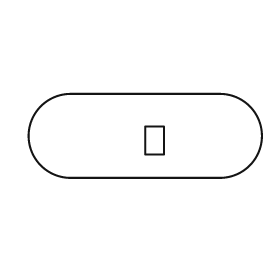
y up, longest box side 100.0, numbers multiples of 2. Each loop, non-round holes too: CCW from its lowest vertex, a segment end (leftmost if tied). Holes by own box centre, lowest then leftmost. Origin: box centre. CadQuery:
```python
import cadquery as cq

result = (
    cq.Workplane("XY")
    .moveTo(-32.0, -18.0)
    .lineTo(32.0, -18.0)
    .threePointArc((50.0, 0.0), (32.0, 18.0))
    .lineTo(-32.0, 18.0)
    .threePointArc((-50.0, 0.0), (-32.0, -18.0))
    .close()
    .moveTo(0.0, -8.0)
    .lineTo(8.0, -8.0)
    .lineTo(8.0, 4.0)
    .lineTo(0.0, 4.0)
    .close()
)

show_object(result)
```